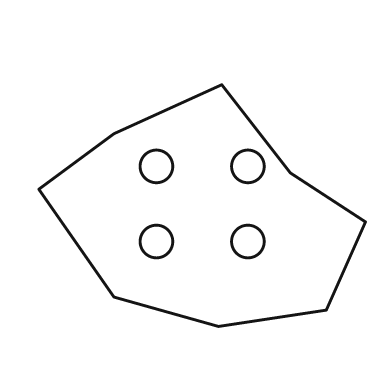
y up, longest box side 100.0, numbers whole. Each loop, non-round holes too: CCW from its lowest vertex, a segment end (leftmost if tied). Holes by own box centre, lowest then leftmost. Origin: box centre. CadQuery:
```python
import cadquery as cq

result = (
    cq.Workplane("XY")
    .moveTo(5.0, -37.0)
    .lineTo(38.0, -32.0)
    .lineTo(50.0, -5.0)
    .lineTo(27.0, 10.0)
    .lineTo(6.0, 37.0)
    .lineTo(-27.0, 22.0)
    .lineTo(-50.0, 5.0)
    .lineTo(-27.0, -28.0)
    .close()
    .moveTo(-14.0, -11.0)
    .circle(5.0)
    .moveTo(14.0, -11.0)
    .circle(5.0)
    .moveTo(-14.0, 12.0)
    .circle(5.0)
    .moveTo(14.0, 12.0)
    .circle(5.0)
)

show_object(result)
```